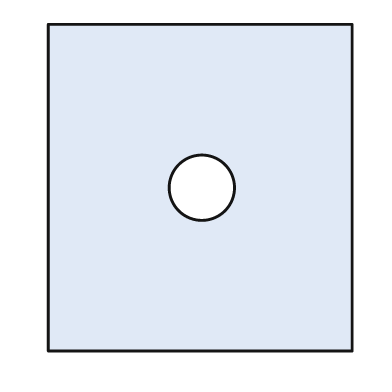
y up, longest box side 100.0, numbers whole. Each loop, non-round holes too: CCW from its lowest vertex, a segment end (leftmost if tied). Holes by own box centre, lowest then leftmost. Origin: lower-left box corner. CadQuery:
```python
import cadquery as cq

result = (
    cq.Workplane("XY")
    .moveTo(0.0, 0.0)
    .lineTo(93.0, 0.0)
    .lineTo(93.0, 100.0)
    .lineTo(0.0, 100.0)
    .close()
    .moveTo(47.0, 50.0)
    .circle(10.0)
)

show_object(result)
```